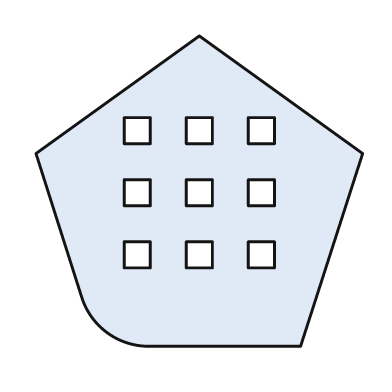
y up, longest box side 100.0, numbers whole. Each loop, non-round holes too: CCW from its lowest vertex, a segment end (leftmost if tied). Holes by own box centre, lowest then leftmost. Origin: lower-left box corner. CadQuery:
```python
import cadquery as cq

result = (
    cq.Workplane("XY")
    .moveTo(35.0, 0.0)
    .lineTo(81.0, 0.0)
    .lineTo(100.0, 59.0)
    .lineTo(50.0, 95.0)
    .lineTo(0.0, 59.0)
    .lineTo(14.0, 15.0)
    .threePointArc((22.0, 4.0), (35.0, 0.0))
    .close()
    .moveTo(27.0, 24.0)
    .lineTo(35.0, 24.0)
    .lineTo(35.0, 32.0)
    .lineTo(27.0, 32.0)
    .close()
    .moveTo(46.0, 24.0)
    .lineTo(54.0, 24.0)
    .lineTo(54.0, 32.0)
    .lineTo(46.0, 32.0)
    .close()
    .moveTo(65.0, 24.0)
    .lineTo(73.0, 24.0)
    .lineTo(73.0, 32.0)
    .lineTo(65.0, 32.0)
    .close()
    .moveTo(27.0, 43.0)
    .lineTo(35.0, 43.0)
    .lineTo(35.0, 51.0)
    .lineTo(27.0, 51.0)
    .close()
    .moveTo(46.0, 43.0)
    .lineTo(54.0, 43.0)
    .lineTo(54.0, 51.0)
    .lineTo(46.0, 51.0)
    .close()
    .moveTo(65.0, 43.0)
    .lineTo(73.0, 43.0)
    .lineTo(73.0, 51.0)
    .lineTo(65.0, 51.0)
    .close()
    .moveTo(27.0, 62.0)
    .lineTo(35.0, 62.0)
    .lineTo(35.0, 70.0)
    .lineTo(27.0, 70.0)
    .close()
    .moveTo(46.0, 62.0)
    .lineTo(54.0, 62.0)
    .lineTo(54.0, 70.0)
    .lineTo(46.0, 70.0)
    .close()
    .moveTo(65.0, 62.0)
    .lineTo(73.0, 62.0)
    .lineTo(73.0, 70.0)
    .lineTo(65.0, 70.0)
    .close()
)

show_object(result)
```